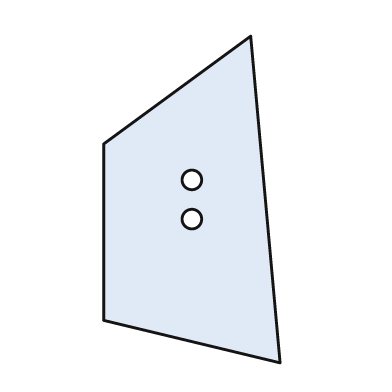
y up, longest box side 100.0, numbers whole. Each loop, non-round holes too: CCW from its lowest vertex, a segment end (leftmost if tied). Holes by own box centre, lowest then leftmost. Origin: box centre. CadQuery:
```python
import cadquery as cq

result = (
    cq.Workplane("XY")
    .moveTo(27.0, -50.0)
    .lineTo(18.0, 50.0)
    .lineTo(-27.0, 17.0)
    .lineTo(-27.0, -37.0)
    .close()
    .moveTo(0.0, -6.0)
    .circle(3.0)
    .moveTo(0.0, 6.0)
    .circle(3.0)
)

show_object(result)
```